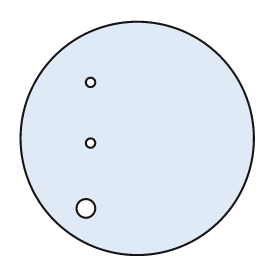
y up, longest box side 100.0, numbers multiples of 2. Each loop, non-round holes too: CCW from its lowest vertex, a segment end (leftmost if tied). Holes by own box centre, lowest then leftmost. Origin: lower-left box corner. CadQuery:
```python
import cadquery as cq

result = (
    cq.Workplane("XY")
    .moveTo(50.0, 50.0)
    .circle(50.0)
    .moveTo(28.0, 20.0)
    .circle(4.0)
    .moveTo(30.0, 48.0)
    .circle(2.0)
    .moveTo(30.0, 74.0)
    .circle(2.0)
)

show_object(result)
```